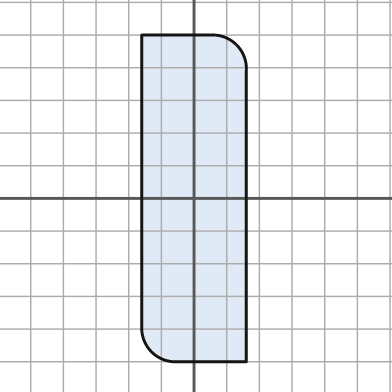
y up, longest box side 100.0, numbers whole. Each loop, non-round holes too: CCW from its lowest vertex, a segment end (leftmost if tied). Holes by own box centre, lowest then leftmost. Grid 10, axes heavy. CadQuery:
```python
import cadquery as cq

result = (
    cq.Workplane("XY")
    .moveTo(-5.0, -50.0)
    .lineTo(16.0, -50.0)
    .lineTo(16.0, 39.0)
    .threePointArc((13.0, 47.0), (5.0, 50.0))
    .lineTo(-16.0, 50.0)
    .lineTo(-16.0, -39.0)
    .threePointArc((-13.0, -47.0), (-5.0, -50.0))
    .close()
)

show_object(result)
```